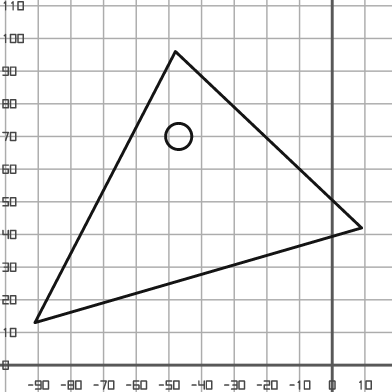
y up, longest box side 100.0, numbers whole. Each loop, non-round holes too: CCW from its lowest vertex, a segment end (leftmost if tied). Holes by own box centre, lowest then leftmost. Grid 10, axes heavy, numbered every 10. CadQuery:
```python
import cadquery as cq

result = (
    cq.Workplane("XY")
    .moveTo(-91.0, 13.0)
    .lineTo(9.0, 42.0)
    .lineTo(-48.0, 96.0)
    .close()
    .moveTo(-47.0, 70.0)
    .circle(4.0)
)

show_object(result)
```